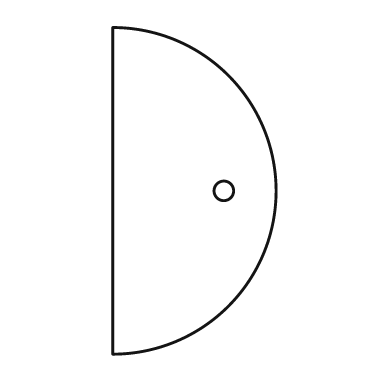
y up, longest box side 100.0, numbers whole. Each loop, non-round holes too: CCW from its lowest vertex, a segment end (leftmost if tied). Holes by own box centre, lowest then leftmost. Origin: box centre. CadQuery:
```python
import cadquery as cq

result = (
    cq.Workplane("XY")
    .moveTo(-25.0, -50.0)
    .threePointArc((25.0, 0.0), (-25.0, 50.0))
    .close()
    .moveTo(9.0, 0.0)
    .circle(3.0)
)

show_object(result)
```